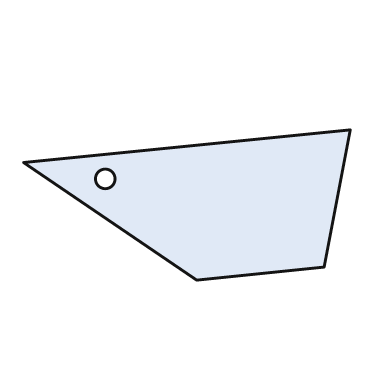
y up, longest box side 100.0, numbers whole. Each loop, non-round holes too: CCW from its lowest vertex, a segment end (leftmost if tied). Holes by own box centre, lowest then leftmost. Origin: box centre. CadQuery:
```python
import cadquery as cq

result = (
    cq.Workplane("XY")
    .moveTo(3.0, -23.0)
    .lineTo(42.0, -19.0)
    .lineTo(50.0, 23.0)
    .lineTo(-50.0, 13.0)
    .close()
    .moveTo(-25.0, 8.0)
    .circle(3.0)
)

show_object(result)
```